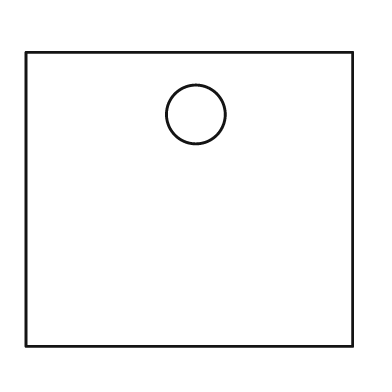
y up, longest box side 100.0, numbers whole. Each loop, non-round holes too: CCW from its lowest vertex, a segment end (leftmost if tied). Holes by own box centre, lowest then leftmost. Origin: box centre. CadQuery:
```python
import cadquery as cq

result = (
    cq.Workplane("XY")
    .moveTo(-50.0, -45.0)
    .lineTo(50.0, -45.0)
    .lineTo(50.0, 45.0)
    .lineTo(-50.0, 45.0)
    .close()
    .moveTo(2.0, 26.0)
    .circle(9.0)
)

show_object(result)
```